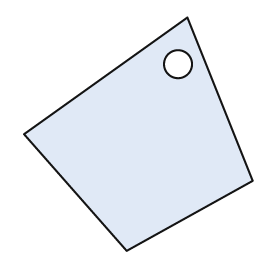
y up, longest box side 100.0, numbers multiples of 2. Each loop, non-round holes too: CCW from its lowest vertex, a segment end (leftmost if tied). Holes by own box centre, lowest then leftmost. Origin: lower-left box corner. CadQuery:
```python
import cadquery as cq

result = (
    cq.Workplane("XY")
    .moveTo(44.0, 0.0)
    .lineTo(98.0, 30.0)
    .lineTo(70.0, 100.0)
    .lineTo(0.0, 50.0)
    .close()
    .moveTo(66.0, 80.0)
    .circle(6.0)
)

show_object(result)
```